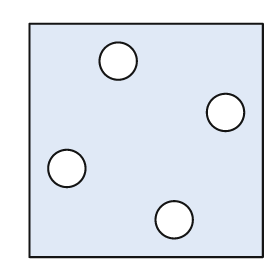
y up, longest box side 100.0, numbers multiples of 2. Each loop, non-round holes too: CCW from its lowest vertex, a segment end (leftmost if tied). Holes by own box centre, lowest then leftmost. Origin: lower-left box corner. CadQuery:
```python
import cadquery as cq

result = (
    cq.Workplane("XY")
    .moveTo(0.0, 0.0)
    .lineTo(100.0, 0.0)
    .lineTo(100.0, 100.0)
    .lineTo(0.0, 100.0)
    .close()
    .moveTo(62.0, 16.0)
    .circle(8.0)
    .moveTo(16.0, 38.0)
    .circle(8.0)
    .moveTo(84.0, 62.0)
    .circle(8.0)
    .moveTo(38.0, 84.0)
    .circle(8.0)
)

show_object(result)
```